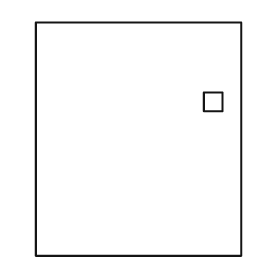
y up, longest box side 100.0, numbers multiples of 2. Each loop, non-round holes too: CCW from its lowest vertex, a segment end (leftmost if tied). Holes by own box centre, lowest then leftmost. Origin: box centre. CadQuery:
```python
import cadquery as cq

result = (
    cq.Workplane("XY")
    .moveTo(-44.0, -50.0)
    .lineTo(44.0, -50.0)
    .lineTo(44.0, 50.0)
    .lineTo(-44.0, 50.0)
    .close()
    .moveTo(28.0, 12.0)
    .lineTo(36.0, 12.0)
    .lineTo(36.0, 20.0)
    .lineTo(28.0, 20.0)
    .close()
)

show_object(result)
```